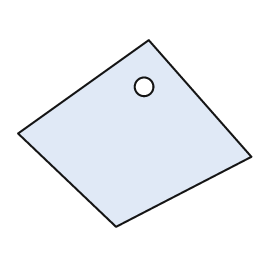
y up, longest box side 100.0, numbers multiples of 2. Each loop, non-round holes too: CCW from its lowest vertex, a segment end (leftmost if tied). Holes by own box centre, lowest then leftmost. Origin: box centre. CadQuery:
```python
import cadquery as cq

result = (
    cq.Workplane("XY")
    .moveTo(-8.0, -40.0)
    .lineTo(50.0, -10.0)
    .lineTo(6.0, 40.0)
    .lineTo(-50.0, 0.0)
    .close()
    .moveTo(4.0, 20.0)
    .circle(4.0)
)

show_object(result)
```